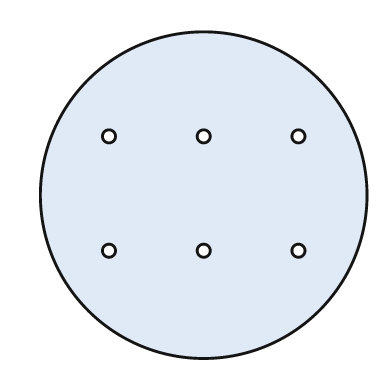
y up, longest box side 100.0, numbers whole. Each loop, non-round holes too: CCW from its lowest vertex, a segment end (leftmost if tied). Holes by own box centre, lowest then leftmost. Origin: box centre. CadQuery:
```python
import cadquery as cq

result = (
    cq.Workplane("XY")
    .moveTo(0.0, 0.0)
    .circle(50.0)
    .moveTo(-29.0, -17.0)
    .circle(2.0)
    .moveTo(0.0, -17.0)
    .circle(2.0)
    .moveTo(29.0, -17.0)
    .circle(2.0)
    .moveTo(-29.0, 18.0)
    .circle(2.0)
    .moveTo(0.0, 18.0)
    .circle(2.0)
    .moveTo(29.0, 18.0)
    .circle(2.0)
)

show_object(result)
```